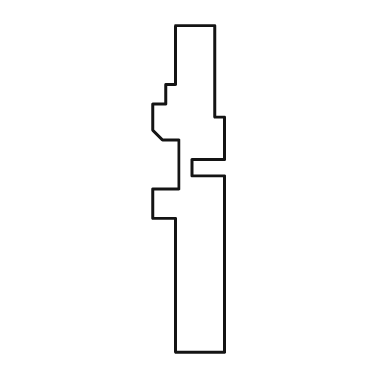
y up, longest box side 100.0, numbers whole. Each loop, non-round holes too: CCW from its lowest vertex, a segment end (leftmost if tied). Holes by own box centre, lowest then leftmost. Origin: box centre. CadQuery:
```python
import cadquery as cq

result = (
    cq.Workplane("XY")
    .moveTo(-4.0, -50.0)
    .lineTo(11.0, -50.0)
    .lineTo(11.0, 4.0)
    .lineTo(1.0, 4.0)
    .lineTo(1.0, 9.0)
    .lineTo(11.0, 9.0)
    .lineTo(11.0, 22.0)
    .lineTo(8.0, 22.0)
    .lineTo(8.0, 50.0)
    .lineTo(-4.0, 50.0)
    .lineTo(-4.0, 32.0)
    .lineTo(-7.0, 32.0)
    .lineTo(-7.0, 26.0)
    .lineTo(-11.0, 26.0)
    .lineTo(-11.0, 18.0)
    .lineTo(-8.0, 15.0)
    .lineTo(-3.0, 15.0)
    .lineTo(-3.0, 0.0)
    .lineTo(-11.0, 0.0)
    .lineTo(-11.0, -9.0)
    .lineTo(-4.0, -9.0)
    .close()
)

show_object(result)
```